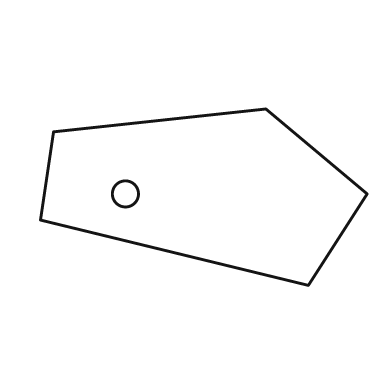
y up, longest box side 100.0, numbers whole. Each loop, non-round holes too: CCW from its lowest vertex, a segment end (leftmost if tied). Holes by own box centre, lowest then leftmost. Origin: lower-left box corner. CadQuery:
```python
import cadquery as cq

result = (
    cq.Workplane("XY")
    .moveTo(82.0, 0.0)
    .lineTo(100.0, 28.0)
    .lineTo(69.0, 54.0)
    .lineTo(4.0, 47.0)
    .lineTo(0.0, 20.0)
    .close()
    .moveTo(26.0, 28.0)
    .circle(4.0)
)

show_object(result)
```